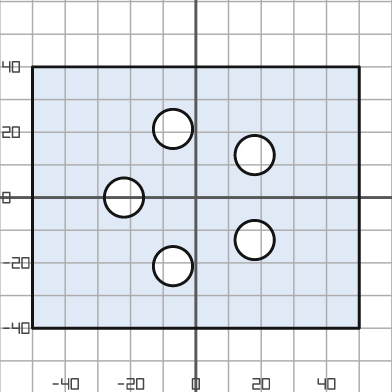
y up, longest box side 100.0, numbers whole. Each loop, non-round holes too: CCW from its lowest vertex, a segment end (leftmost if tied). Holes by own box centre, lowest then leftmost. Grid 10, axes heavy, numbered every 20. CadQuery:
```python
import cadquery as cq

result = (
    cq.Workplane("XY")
    .moveTo(-50.0, -40.0)
    .lineTo(50.0, -40.0)
    .lineTo(50.0, 40.0)
    .lineTo(-50.0, 40.0)
    .close()
    .moveTo(-7.0, -21.0)
    .circle(6.0)
    .moveTo(18.0, -13.0)
    .circle(6.0)
    .moveTo(-22.0, 0.0)
    .circle(6.0)
    .moveTo(18.0, 13.0)
    .circle(6.0)
    .moveTo(-7.0, 21.0)
    .circle(6.0)
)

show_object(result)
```